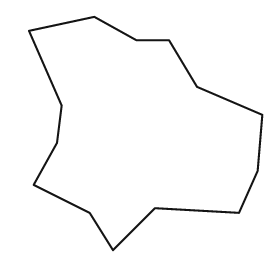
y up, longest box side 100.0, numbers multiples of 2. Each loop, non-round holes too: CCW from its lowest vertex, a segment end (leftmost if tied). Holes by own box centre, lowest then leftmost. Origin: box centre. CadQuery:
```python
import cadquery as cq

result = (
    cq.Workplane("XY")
    .moveTo(-14.0, -50.0)
    .lineTo(4.0, -32.0)
    .lineTo(40.0, -34.0)
    .lineTo(48.0, -16.0)
    .lineTo(50.0, 8.0)
    .lineTo(22.0, 20.0)
    .lineTo(10.0, 40.0)
    .lineTo(-4.0, 40.0)
    .lineTo(-22.0, 50.0)
    .lineTo(-50.0, 44.0)
    .lineTo(-36.0, 12.0)
    .lineTo(-38.0, -4.0)
    .lineTo(-48.0, -22.0)
    .lineTo(-24.0, -34.0)
    .close()
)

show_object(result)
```